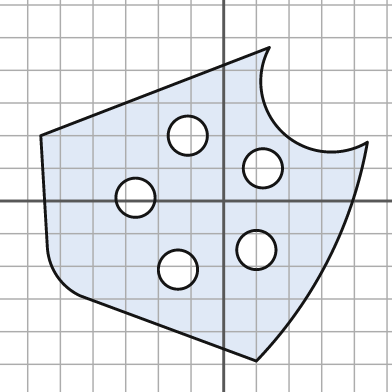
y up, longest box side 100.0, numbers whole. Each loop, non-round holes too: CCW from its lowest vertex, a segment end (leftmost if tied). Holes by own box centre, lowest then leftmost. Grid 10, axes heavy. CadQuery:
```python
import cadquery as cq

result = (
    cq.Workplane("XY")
    .moveTo(10.0, -49.0)
    .threePointArc((32.0, -18.0), (44.0, 18.0))
    .threePointArc((18.0, 21.0), (14.0, 47.0))
    .lineTo(-56.0, 20.0)
    .lineTo(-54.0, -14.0)
    .threePointArc((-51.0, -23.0), (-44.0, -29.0))
    .close()
    .moveTo(-14.0, -21.0)
    .circle(6.0)
    .moveTo(10.0, -15.0)
    .circle(6.0)
    .moveTo(-27.0, 1.0)
    .circle(6.0)
    .moveTo(12.0, 10.0)
    .circle(6.0)
    .moveTo(-11.0, 20.0)
    .circle(6.0)
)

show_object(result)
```